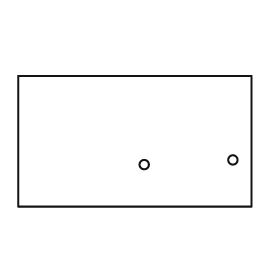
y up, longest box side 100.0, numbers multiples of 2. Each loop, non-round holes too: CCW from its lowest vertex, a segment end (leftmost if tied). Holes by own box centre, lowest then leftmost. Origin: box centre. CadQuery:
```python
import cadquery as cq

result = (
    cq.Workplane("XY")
    .moveTo(-50.0, -28.0)
    .lineTo(50.0, -28.0)
    .lineTo(50.0, 28.0)
    .lineTo(-50.0, 28.0)
    .close()
    .moveTo(4.0, -10.0)
    .circle(2.0)
    .moveTo(42.0, -8.0)
    .circle(2.0)
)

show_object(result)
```